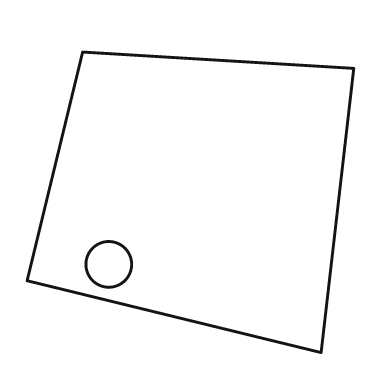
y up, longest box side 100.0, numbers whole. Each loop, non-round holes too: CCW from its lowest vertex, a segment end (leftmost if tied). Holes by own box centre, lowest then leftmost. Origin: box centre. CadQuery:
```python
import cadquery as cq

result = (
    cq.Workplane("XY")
    .moveTo(40.0, -46.0)
    .lineTo(50.0, 41.0)
    .lineTo(-33.0, 46.0)
    .lineTo(-50.0, -24.0)
    .close()
    .moveTo(-25.0, -19.0)
    .circle(7.0)
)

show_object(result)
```